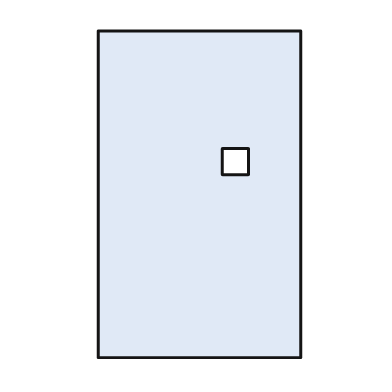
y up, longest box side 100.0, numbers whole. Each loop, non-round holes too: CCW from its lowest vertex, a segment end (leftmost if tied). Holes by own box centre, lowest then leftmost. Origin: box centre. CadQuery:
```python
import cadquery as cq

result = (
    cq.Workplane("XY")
    .moveTo(-31.0, -50.0)
    .lineTo(31.0, -50.0)
    .lineTo(31.0, 50.0)
    .lineTo(-31.0, 50.0)
    .close()
    .moveTo(7.0, 6.0)
    .lineTo(15.0, 6.0)
    .lineTo(15.0, 14.0)
    .lineTo(7.0, 14.0)
    .close()
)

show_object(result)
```